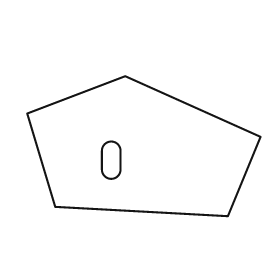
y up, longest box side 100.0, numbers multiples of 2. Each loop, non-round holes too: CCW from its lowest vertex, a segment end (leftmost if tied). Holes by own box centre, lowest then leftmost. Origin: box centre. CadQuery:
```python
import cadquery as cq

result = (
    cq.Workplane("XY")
    .moveTo(36.0, -30.0)
    .lineTo(50.0, 4.0)
    .lineTo(-8.0, 30.0)
    .lineTo(-50.0, 14.0)
    .lineTo(-38.0, -26.0)
    .close()
    .moveTo(-18.0, -10.0)
    .threePointArc((-14.0, -14.0), (-10.0, -10.0))
    .lineTo(-10.0, -2.0)
    .threePointArc((-14.0, 2.0), (-18.0, -2.0))
    .close()
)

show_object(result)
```